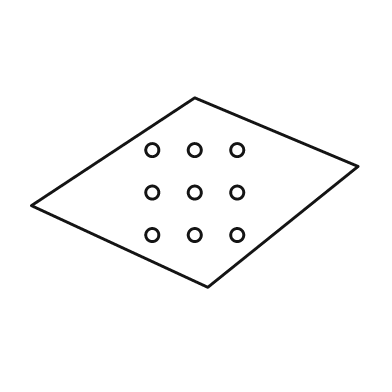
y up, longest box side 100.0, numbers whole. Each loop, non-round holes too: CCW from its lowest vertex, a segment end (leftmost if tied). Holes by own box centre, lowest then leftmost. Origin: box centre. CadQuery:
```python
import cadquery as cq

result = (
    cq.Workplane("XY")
    .moveTo(4.0, -29.0)
    .lineTo(50.0, 8.0)
    .lineTo(0.0, 29.0)
    .lineTo(-50.0, -4.0)
    .close()
    .moveTo(-13.0, -13.0)
    .circle(2.0)
    .moveTo(0.0, -13.0)
    .circle(2.0)
    .moveTo(13.0, -13.0)
    .circle(2.0)
    .moveTo(-13.0, 0.0)
    .circle(2.0)
    .moveTo(0.0, 0.0)
    .circle(2.0)
    .moveTo(13.0, 0.0)
    .circle(2.0)
    .moveTo(-13.0, 13.0)
    .circle(2.0)
    .moveTo(0.0, 13.0)
    .circle(2.0)
    .moveTo(13.0, 13.0)
    .circle(2.0)
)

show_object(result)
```